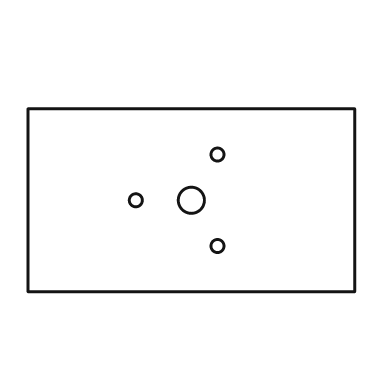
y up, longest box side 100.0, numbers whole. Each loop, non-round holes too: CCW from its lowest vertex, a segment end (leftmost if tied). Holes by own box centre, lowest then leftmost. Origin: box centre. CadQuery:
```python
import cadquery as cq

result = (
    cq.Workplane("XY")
    .moveTo(-50.0, -28.0)
    .lineTo(50.0, -28.0)
    .lineTo(50.0, 28.0)
    .lineTo(-50.0, 28.0)
    .close()
    .moveTo(8.0, -14.0)
    .circle(2.0)
    .moveTo(-17.0, 0.0)
    .circle(2.0)
    .moveTo(0.0, 0.0)
    .circle(4.0)
    .moveTo(8.0, 14.0)
    .circle(2.0)
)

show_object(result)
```